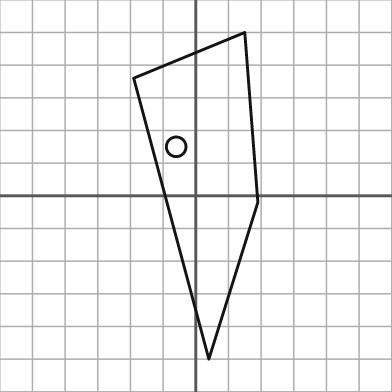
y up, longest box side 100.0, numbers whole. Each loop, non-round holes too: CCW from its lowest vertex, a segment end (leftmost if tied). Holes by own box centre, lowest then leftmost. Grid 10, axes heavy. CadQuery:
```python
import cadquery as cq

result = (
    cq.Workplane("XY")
    .moveTo(4.0, -50.0)
    .lineTo(19.0, -2.0)
    .lineTo(15.0, 50.0)
    .lineTo(-19.0, 36.0)
    .close()
    .moveTo(-6.0, 15.0)
    .circle(3.0)
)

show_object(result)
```